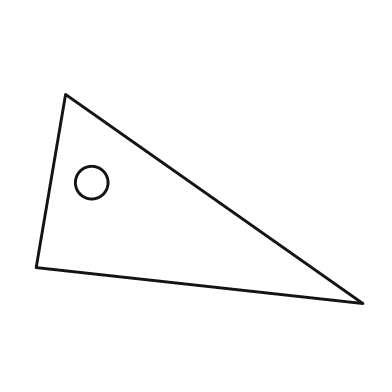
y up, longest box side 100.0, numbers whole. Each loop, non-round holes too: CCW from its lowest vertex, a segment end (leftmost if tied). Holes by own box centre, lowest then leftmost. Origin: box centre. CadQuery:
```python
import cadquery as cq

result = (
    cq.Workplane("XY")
    .moveTo(50.0, -32.0)
    .lineTo(-41.0, 32.0)
    .lineTo(-50.0, -21.0)
    .close()
    .moveTo(-33.0, 5.0)
    .circle(5.0)
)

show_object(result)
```